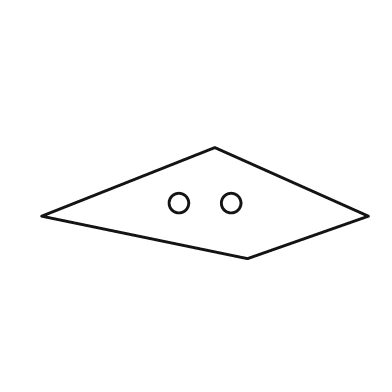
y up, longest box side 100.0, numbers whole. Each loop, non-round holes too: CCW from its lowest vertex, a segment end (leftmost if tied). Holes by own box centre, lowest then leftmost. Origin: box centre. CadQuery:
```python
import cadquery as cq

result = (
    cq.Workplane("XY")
    .moveTo(13.0, -17.0)
    .lineTo(50.0, -4.0)
    .lineTo(3.0, 17.0)
    .lineTo(-50.0, -4.0)
    .close()
    .moveTo(-8.0, 0.0)
    .circle(3.0)
    .moveTo(8.0, 0.0)
    .circle(3.0)
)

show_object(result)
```